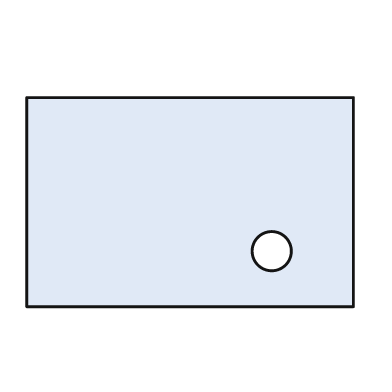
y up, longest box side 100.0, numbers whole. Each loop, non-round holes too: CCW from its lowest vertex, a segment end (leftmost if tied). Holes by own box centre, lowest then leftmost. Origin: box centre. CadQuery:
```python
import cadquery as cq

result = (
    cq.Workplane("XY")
    .moveTo(-50.0, -32.0)
    .lineTo(50.0, -32.0)
    .lineTo(50.0, 32.0)
    .lineTo(-50.0, 32.0)
    .close()
    .moveTo(25.0, -15.0)
    .circle(6.0)
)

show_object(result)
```